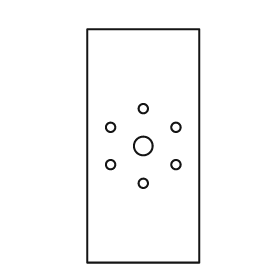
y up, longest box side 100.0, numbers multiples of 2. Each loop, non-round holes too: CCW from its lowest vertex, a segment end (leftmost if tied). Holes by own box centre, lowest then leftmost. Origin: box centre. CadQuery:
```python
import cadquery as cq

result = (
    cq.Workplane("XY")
    .moveTo(-24.0, -50.0)
    .lineTo(24.0, -50.0)
    .lineTo(24.0, 50.0)
    .lineTo(-24.0, 50.0)
    .close()
    .moveTo(0.0, -16.0)
    .circle(2.0)
    .moveTo(-14.0, -8.0)
    .circle(2.0)
    .moveTo(14.0, -8.0)
    .circle(2.0)
    .moveTo(0.0, 0.0)
    .circle(4.0)
    .moveTo(-14.0, 8.0)
    .circle(2.0)
    .moveTo(14.0, 8.0)
    .circle(2.0)
    .moveTo(0.0, 16.0)
    .circle(2.0)
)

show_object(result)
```